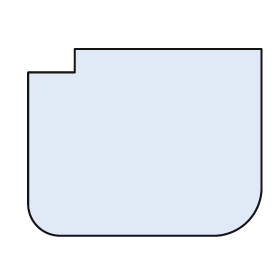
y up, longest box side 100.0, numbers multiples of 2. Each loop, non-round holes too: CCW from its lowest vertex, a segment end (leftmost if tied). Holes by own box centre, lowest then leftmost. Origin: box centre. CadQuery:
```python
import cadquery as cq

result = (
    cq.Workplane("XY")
    .moveTo(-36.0, -40.0)
    .lineTo(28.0, -40.0)
    .threePointArc((44.0, -34.0), (50.0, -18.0))
    .lineTo(50.0, 40.0)
    .lineTo(-30.0, 40.0)
    .lineTo(-30.0, 30.0)
    .lineTo(-50.0, 30.0)
    .lineTo(-50.0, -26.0)
    .threePointArc((-46.0, -36.0), (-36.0, -40.0))
    .close()
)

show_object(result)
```